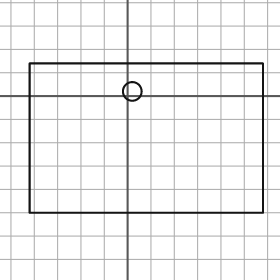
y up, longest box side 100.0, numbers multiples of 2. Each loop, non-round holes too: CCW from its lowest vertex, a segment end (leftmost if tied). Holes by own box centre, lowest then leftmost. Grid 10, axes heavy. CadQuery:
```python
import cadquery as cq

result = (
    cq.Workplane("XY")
    .moveTo(-42.0, -50.0)
    .lineTo(58.0, -50.0)
    .lineTo(58.0, 14.0)
    .lineTo(-42.0, 14.0)
    .close()
    .moveTo(2.0, 2.0)
    .circle(4.0)
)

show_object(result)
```